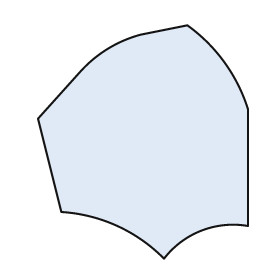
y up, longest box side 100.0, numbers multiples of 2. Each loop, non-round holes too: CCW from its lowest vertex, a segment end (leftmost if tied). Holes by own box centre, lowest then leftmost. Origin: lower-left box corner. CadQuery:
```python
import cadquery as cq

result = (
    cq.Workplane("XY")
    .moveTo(54.0, 0.0)
    .threePointArc((70.0, 12.0), (90.0, 14.0))
    .lineTo(90.0, 64.0)
    .threePointArc((80.0, 84.0), (64.0, 100.0))
    .lineTo(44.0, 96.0)
    .threePointArc((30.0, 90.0), (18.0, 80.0))
    .lineTo(0.0, 60.0)
    .lineTo(10.0, 20.0)
    .threePointArc((34.0, 14.0), (54.0, 0.0))
    .close()
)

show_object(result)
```